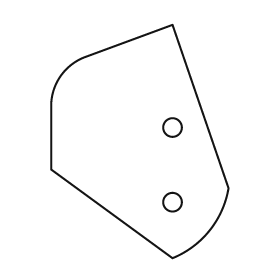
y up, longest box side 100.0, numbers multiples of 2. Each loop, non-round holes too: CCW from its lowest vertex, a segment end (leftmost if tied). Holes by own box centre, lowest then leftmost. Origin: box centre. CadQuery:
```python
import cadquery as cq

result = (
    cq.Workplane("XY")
    .moveTo(14.0, -50.0)
    .threePointArc((30.0, -38.0), (38.0, -20.0))
    .lineTo(14.0, 50.0)
    .lineTo(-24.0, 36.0)
    .threePointArc((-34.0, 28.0), (-38.0, 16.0))
    .lineTo(-38.0, -12.0)
    .close()
    .moveTo(14.0, -26.0)
    .circle(4.0)
    .moveTo(14.0, 6.0)
    .circle(4.0)
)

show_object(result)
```